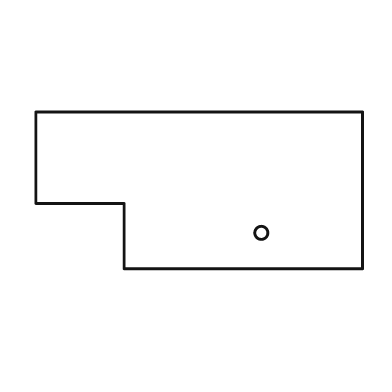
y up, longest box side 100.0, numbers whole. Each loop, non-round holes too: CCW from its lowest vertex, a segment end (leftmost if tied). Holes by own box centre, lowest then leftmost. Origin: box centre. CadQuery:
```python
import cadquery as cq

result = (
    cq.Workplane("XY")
    .moveTo(-23.0, -24.0)
    .lineTo(50.0, -24.0)
    .lineTo(50.0, 24.0)
    .lineTo(-50.0, 24.0)
    .lineTo(-50.0, -4.0)
    .lineTo(-23.0, -4.0)
    .close()
    .moveTo(19.0, -13.0)
    .circle(2.0)
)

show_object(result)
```